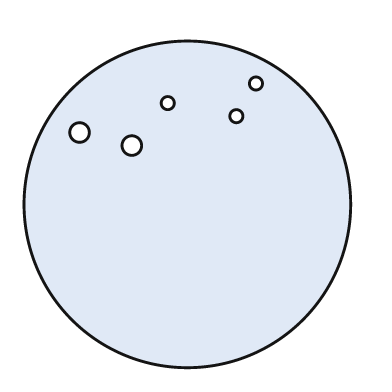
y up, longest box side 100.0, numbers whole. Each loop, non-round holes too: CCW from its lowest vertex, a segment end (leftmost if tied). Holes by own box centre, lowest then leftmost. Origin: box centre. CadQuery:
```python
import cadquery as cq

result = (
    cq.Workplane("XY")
    .moveTo(0.0, 0.0)
    .circle(50.0)
    .moveTo(-17.0, 18.0)
    .circle(3.0)
    .moveTo(-33.0, 22.0)
    .circle(3.0)
    .moveTo(15.0, 27.0)
    .circle(2.0)
    .moveTo(-6.0, 31.0)
    .circle(2.0)
    .moveTo(21.0, 37.0)
    .circle(2.0)
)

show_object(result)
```